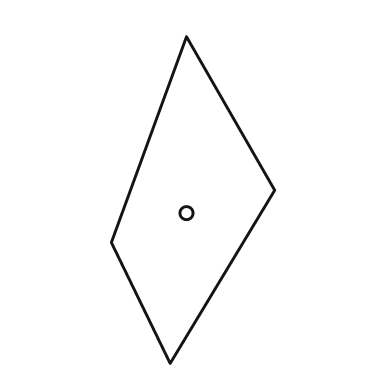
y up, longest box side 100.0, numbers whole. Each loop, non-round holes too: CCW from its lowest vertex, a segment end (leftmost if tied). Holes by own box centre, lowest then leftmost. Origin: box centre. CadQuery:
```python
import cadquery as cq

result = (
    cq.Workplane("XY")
    .moveTo(-7.0, -50.0)
    .lineTo(25.0, 3.0)
    .lineTo(-2.0, 50.0)
    .lineTo(-25.0, -13.0)
    .close()
    .moveTo(-2.0, -4.0)
    .circle(2.0)
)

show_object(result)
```